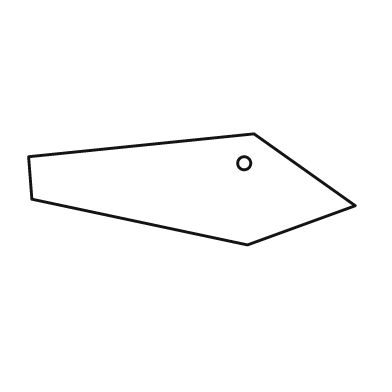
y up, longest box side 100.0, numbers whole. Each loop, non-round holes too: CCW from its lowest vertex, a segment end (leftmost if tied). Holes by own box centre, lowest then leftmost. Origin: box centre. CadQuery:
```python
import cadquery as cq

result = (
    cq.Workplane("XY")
    .moveTo(17.0, -17.0)
    .lineTo(50.0, -5.0)
    .lineTo(19.0, 17.0)
    .lineTo(-50.0, 10.0)
    .lineTo(-49.0, -3.0)
    .close()
    .moveTo(16.0, 8.0)
    .circle(2.0)
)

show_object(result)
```